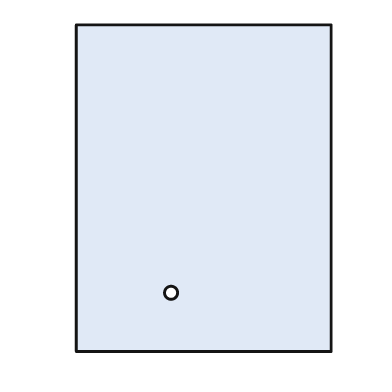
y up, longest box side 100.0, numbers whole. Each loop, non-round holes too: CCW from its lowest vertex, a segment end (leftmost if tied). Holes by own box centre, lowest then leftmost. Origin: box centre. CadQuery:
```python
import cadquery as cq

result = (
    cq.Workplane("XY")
    .moveTo(-39.0, -50.0)
    .lineTo(39.0, -50.0)
    .lineTo(39.0, 50.0)
    .lineTo(-39.0, 50.0)
    .close()
    .moveTo(-10.0, -32.0)
    .circle(2.0)
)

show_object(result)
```